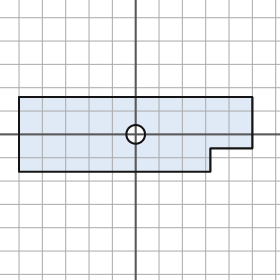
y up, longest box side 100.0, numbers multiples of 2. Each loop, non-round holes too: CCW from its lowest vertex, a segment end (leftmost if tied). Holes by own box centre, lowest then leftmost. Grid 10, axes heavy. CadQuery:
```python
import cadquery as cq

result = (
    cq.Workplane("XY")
    .moveTo(-50.0, -16.0)
    .lineTo(32.0, -16.0)
    .lineTo(32.0, -6.0)
    .lineTo(50.0, -6.0)
    .lineTo(50.0, 16.0)
    .lineTo(-50.0, 16.0)
    .close()
    .moveTo(0.0, 0.0)
    .circle(4.0)
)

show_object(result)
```